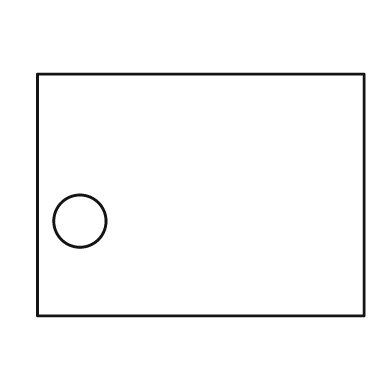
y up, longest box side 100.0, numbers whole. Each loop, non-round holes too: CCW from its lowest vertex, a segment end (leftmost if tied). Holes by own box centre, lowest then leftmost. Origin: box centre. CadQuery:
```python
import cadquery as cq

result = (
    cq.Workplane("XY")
    .moveTo(-50.0, -37.0)
    .lineTo(50.0, -37.0)
    .lineTo(50.0, 37.0)
    .lineTo(-50.0, 37.0)
    .close()
    .moveTo(-37.0, -8.0)
    .circle(8.0)
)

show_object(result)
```